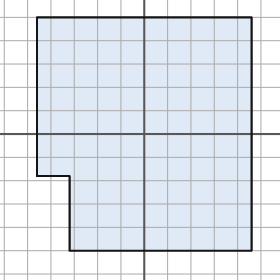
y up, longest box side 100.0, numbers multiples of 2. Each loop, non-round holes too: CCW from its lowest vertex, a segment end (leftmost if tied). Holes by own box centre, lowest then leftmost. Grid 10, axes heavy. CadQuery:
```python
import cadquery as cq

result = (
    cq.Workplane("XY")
    .moveTo(-32.0, -50.0)
    .lineTo(46.0, -50.0)
    .lineTo(46.0, 50.0)
    .lineTo(-46.0, 50.0)
    .lineTo(-46.0, -18.0)
    .lineTo(-32.0, -18.0)
    .close()
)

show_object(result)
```